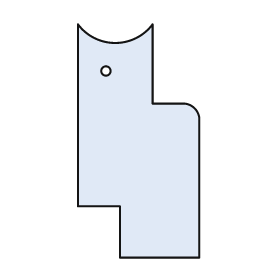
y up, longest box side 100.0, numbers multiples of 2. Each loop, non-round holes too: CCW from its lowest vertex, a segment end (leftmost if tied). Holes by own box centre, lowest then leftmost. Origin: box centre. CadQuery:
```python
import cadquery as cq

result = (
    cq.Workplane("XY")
    .moveTo(-8.0, -50.0)
    .lineTo(26.0, -50.0)
    .lineTo(26.0, 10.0)
    .threePointArc((24.0, 14.0), (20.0, 16.0))
    .lineTo(6.0, 16.0)
    .lineTo(6.0, 50.0)
    .threePointArc((-10.0, 42.0), (-26.0, 50.0))
    .lineTo(-26.0, -28.0)
    .lineTo(-8.0, -28.0)
    .close()
    .moveTo(-14.0, 30.0)
    .circle(2.0)
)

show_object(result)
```